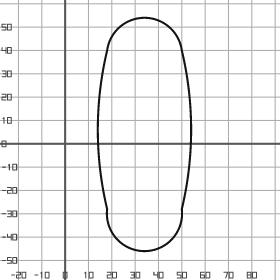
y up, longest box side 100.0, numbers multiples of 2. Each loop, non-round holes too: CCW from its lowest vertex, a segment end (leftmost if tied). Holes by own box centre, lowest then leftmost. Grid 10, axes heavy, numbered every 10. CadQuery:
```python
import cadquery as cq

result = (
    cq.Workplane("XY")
    .moveTo(18.0, -28.0)
    .threePointArc((34.0, -46.0), (50.0, -28.0))
    .threePointArc((54.0, 6.0), (50.0, 40.0))
    .threePointArc((34.0, 54.0), (18.0, 40.0))
    .threePointArc((14.0, 6.0), (18.0, -28.0))
    .close()
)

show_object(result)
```